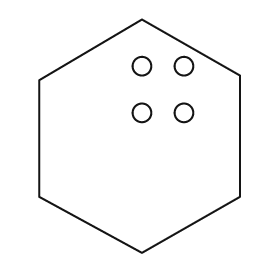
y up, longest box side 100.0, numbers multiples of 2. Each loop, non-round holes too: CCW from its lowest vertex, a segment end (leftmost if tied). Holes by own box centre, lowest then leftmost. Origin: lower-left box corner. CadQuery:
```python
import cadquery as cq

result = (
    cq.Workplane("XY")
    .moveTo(44.0, 0.0)
    .lineTo(86.0, 24.0)
    .lineTo(86.0, 76.0)
    .lineTo(44.0, 100.0)
    .lineTo(0.0, 74.0)
    .lineTo(0.0, 24.0)
    .close()
    .moveTo(44.0, 60.0)
    .circle(4.0)
    .moveTo(62.0, 60.0)
    .circle(4.0)
    .moveTo(44.0, 80.0)
    .circle(4.0)
    .moveTo(62.0, 80.0)
    .circle(4.0)
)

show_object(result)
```